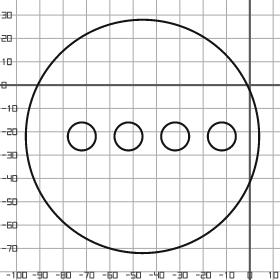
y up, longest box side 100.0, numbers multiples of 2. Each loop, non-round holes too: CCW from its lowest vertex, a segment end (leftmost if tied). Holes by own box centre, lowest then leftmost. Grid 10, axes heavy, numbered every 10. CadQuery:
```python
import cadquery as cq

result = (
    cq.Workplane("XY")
    .moveTo(-46.0, -22.0)
    .circle(50.0)
    .moveTo(-72.0, -22.0)
    .circle(6.0)
    .moveTo(-52.0, -22.0)
    .circle(6.0)
    .moveTo(-32.0, -22.0)
    .circle(6.0)
    .moveTo(-12.0, -22.0)
    .circle(6.0)
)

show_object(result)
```